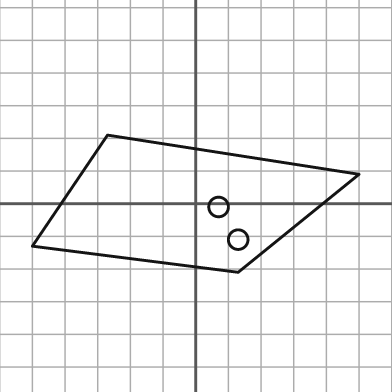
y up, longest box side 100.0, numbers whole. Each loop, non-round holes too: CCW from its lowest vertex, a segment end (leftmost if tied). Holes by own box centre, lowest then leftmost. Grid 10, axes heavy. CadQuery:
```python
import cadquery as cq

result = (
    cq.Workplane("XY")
    .moveTo(13.0, -21.0)
    .lineTo(50.0, 9.0)
    .lineTo(-27.0, 21.0)
    .lineTo(-50.0, -13.0)
    .close()
    .moveTo(13.0, -11.0)
    .circle(3.0)
    .moveTo(7.0, -1.0)
    .circle(3.0)
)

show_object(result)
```